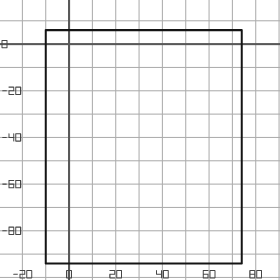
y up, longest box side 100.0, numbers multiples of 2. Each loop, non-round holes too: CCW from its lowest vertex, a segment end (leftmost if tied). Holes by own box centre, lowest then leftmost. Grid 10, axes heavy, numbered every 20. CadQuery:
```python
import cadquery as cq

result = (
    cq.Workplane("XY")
    .moveTo(-10.0, -94.0)
    .lineTo(74.0, -94.0)
    .lineTo(74.0, 6.0)
    .lineTo(-10.0, 6.0)
    .close()
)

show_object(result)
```